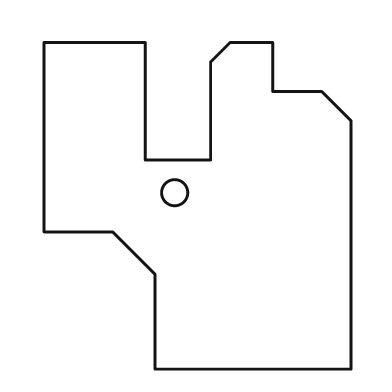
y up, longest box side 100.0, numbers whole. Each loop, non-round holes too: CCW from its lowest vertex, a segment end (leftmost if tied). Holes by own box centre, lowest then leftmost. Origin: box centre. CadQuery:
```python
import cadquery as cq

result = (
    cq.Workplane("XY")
    .moveTo(-13.0, -50.0)
    .lineTo(47.0, -50.0)
    .lineTo(47.0, 26.0)
    .lineTo(38.0, 35.0)
    .lineTo(23.0, 35.0)
    .lineTo(23.0, 50.0)
    .lineTo(10.0, 50.0)
    .lineTo(4.0, 44.0)
    .lineTo(4.0, 14.0)
    .lineTo(-16.0, 14.0)
    .lineTo(-16.0, 50.0)
    .lineTo(-47.0, 50.0)
    .lineTo(-47.0, -8.0)
    .lineTo(-26.0, -8.0)
    .lineTo(-13.0, -21.0)
    .close()
    .moveTo(-7.0, 4.0)
    .circle(4.0)
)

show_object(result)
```